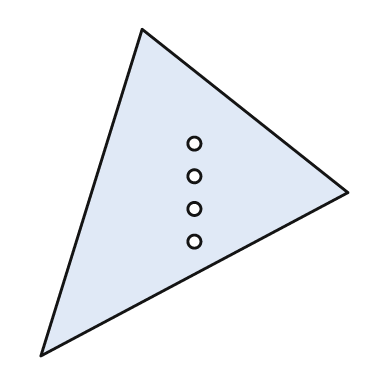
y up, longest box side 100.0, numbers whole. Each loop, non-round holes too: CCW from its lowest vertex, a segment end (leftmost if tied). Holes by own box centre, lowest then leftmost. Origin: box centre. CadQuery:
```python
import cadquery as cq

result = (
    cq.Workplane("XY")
    .moveTo(-47.0, -50.0)
    .lineTo(47.0, 0.0)
    .lineTo(-16.0, 50.0)
    .close()
    .moveTo(0.0, -15.0)
    .circle(2.0)
    .moveTo(0.0, -5.0)
    .circle(2.0)
    .moveTo(0.0, 5.0)
    .circle(2.0)
    .moveTo(0.0, 15.0)
    .circle(2.0)
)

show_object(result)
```